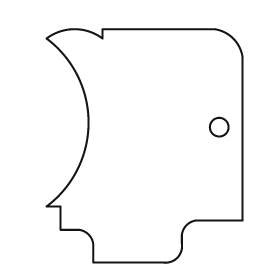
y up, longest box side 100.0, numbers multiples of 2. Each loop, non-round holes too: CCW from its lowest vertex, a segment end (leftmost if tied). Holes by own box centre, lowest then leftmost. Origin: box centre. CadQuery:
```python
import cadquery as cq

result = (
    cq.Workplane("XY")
    .moveTo(-22.0, -50.0)
    .lineTo(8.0, -50.0)
    .threePointArc((14.0, -48.0), (16.0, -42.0))
    .lineTo(16.0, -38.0)
    .threePointArc((18.0, -34.0), (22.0, -32.0))
    .lineTo(42.0, -32.0)
    .lineTo(42.0, 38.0)
    .threePointArc((38.0, 46.0), (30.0, 50.0))
    .lineTo(-18.0, 50.0)
    .lineTo(-18.0, 46.0)
    .threePointArc((-30.0, 50.0), (-42.0, 46.0))
    .threePointArc((-24.0, 10.0), (-42.0, -26.0))
    .lineTo(-36.0, -26.0)
    .lineTo(-36.0, -36.0)
    .lineTo(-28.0, -36.0)
    .threePointArc((-24.0, -38.0), (-22.0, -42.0))
    .close()
    .moveTo(32.0, 8.0)
    .circle(4.0)
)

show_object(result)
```